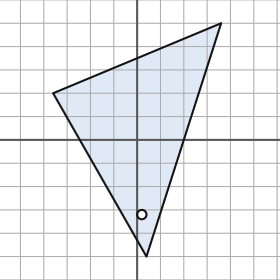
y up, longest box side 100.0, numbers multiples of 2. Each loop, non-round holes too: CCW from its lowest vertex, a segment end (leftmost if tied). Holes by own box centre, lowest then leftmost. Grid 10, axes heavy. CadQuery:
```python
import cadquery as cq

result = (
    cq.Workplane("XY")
    .moveTo(4.0, -50.0)
    .lineTo(36.0, 50.0)
    .lineTo(-36.0, 20.0)
    .close()
    .moveTo(2.0, -32.0)
    .circle(2.0)
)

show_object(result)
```